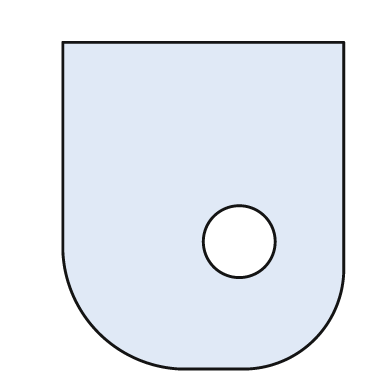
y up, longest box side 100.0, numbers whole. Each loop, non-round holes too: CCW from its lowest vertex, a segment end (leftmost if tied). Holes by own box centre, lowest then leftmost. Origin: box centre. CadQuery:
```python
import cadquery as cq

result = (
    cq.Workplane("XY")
    .moveTo(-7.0, -50.0)
    .lineTo(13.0, -50.0)
    .threePointArc((34.0, -41.0), (43.0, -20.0))
    .lineTo(43.0, 50.0)
    .lineTo(-43.0, 50.0)
    .lineTo(-43.0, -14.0)
    .threePointArc((-32.0, -39.0), (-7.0, -50.0))
    .close()
    .moveTo(11.0, -11.0)
    .circle(11.0)
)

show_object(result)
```